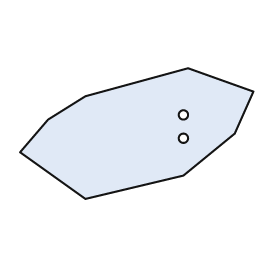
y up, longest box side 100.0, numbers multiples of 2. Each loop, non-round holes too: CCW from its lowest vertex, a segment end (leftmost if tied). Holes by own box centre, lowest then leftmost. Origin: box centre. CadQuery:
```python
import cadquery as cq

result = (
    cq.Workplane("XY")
    .moveTo(-22.0, -28.0)
    .lineTo(20.0, -18.0)
    .lineTo(42.0, 0.0)
    .lineTo(50.0, 18.0)
    .lineTo(22.0, 28.0)
    .lineTo(-22.0, 16.0)
    .lineTo(-38.0, 6.0)
    .lineTo(-50.0, -8.0)
    .close()
    .moveTo(20.0, -2.0)
    .circle(2.0)
    .moveTo(20.0, 8.0)
    .circle(2.0)
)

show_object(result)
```